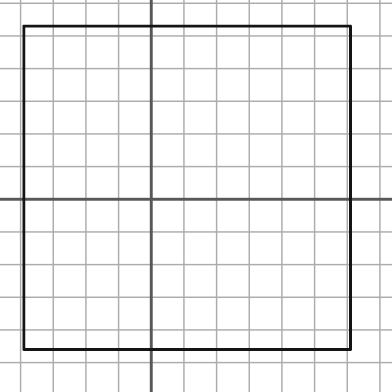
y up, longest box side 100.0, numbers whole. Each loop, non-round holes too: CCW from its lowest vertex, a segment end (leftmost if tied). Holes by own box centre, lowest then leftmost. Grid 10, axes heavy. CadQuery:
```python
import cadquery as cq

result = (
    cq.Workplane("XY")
    .moveTo(-39.0, -46.0)
    .lineTo(61.0, -46.0)
    .lineTo(61.0, 53.0)
    .lineTo(-39.0, 53.0)
    .close()
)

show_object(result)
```